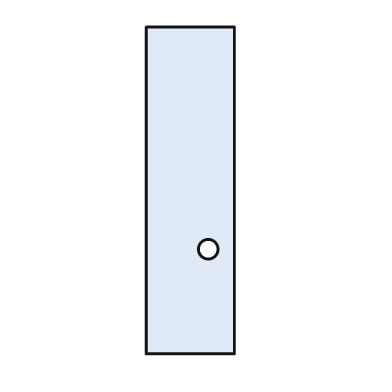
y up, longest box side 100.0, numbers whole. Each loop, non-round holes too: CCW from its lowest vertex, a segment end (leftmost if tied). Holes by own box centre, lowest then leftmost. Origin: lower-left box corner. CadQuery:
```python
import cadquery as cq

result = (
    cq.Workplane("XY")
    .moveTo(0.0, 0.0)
    .lineTo(27.0, 0.0)
    .lineTo(27.0, 100.0)
    .lineTo(0.0, 100.0)
    .close()
    .moveTo(19.0, 32.0)
    .circle(3.0)
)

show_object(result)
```